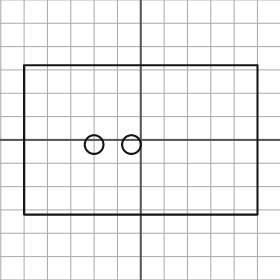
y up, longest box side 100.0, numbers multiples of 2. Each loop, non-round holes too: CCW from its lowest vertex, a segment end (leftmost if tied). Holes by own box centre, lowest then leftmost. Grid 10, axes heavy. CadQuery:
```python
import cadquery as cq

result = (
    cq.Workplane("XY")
    .moveTo(-50.0, -32.0)
    .lineTo(50.0, -32.0)
    .lineTo(50.0, 32.0)
    .lineTo(-50.0, 32.0)
    .close()
    .moveTo(-20.0, -2.0)
    .circle(4.0)
    .moveTo(-4.0, -2.0)
    .circle(4.0)
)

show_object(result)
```